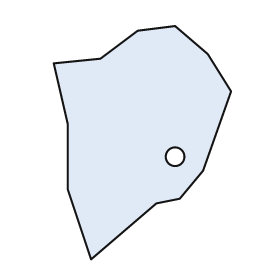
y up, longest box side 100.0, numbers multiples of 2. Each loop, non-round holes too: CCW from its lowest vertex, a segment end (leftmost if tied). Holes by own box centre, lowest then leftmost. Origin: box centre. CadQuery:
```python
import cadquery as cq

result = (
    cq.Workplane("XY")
    .moveTo(-22.0, -50.0)
    .lineTo(6.0, -26.0)
    .lineTo(16.0, -24.0)
    .lineTo(26.0, -12.0)
    .lineTo(38.0, 22.0)
    .lineTo(28.0, 38.0)
    .lineTo(14.0, 50.0)
    .lineTo(-2.0, 48.0)
    .lineTo(-18.0, 36.0)
    .lineTo(-38.0, 34.0)
    .lineTo(-32.0, 8.0)
    .lineTo(-32.0, -20.0)
    .close()
    .moveTo(14.0, -6.0)
    .circle(4.0)
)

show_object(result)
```